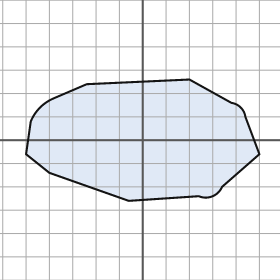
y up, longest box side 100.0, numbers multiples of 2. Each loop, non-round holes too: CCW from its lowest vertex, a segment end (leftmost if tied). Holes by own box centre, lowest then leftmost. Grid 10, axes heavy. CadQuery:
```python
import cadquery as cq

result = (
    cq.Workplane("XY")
    .moveTo(-6.0, -26.0)
    .lineTo(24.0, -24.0)
    .threePointArc((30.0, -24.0), (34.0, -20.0))
    .lineTo(50.0, -6.0)
    .lineTo(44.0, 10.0)
    .threePointArc((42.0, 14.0), (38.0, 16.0))
    .lineTo(20.0, 26.0)
    .lineTo(-24.0, 24.0)
    .lineTo(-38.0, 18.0)
    .threePointArc((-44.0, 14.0), (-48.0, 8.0))
    .lineTo(-50.0, -6.0)
    .lineTo(-40.0, -14.0)
    .close()
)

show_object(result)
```